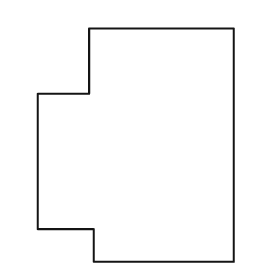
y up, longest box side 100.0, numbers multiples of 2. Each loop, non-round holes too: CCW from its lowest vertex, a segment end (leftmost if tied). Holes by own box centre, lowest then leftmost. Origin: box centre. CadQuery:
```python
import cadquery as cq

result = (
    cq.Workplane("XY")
    .moveTo(-18.0, -50.0)
    .lineTo(42.0, -50.0)
    .lineTo(42.0, 50.0)
    .lineTo(-20.0, 50.0)
    .lineTo(-20.0, 22.0)
    .lineTo(-42.0, 22.0)
    .lineTo(-42.0, -36.0)
    .lineTo(-18.0, -36.0)
    .close()
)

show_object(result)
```